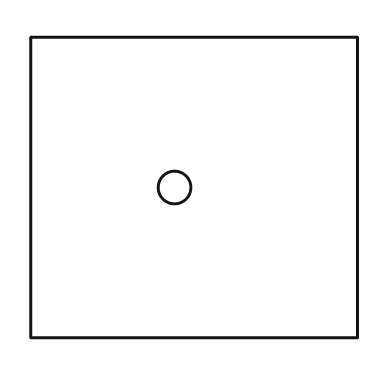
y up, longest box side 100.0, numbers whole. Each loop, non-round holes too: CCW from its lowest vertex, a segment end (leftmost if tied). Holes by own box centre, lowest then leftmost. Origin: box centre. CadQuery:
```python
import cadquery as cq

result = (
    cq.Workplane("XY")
    .moveTo(-50.0, -46.0)
    .lineTo(50.0, -46.0)
    .lineTo(50.0, 46.0)
    .lineTo(-50.0, 46.0)
    .close()
    .moveTo(-6.0, 0.0)
    .circle(5.0)
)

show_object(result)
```